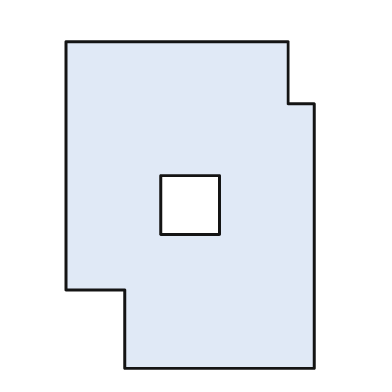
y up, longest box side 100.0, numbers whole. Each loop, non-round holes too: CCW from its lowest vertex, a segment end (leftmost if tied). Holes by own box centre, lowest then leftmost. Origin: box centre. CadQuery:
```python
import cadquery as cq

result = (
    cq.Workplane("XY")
    .moveTo(-20.0, -50.0)
    .lineTo(38.0, -50.0)
    .lineTo(38.0, 31.0)
    .lineTo(30.0, 31.0)
    .lineTo(30.0, 50.0)
    .lineTo(-38.0, 50.0)
    .lineTo(-38.0, -26.0)
    .lineTo(-20.0, -26.0)
    .close()
    .moveTo(-9.0, -9.0)
    .lineTo(9.0, -9.0)
    .lineTo(9.0, 9.0)
    .lineTo(-9.0, 9.0)
    .close()
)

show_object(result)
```